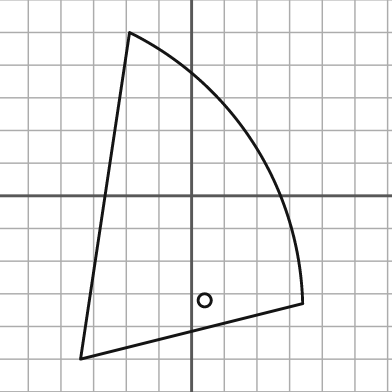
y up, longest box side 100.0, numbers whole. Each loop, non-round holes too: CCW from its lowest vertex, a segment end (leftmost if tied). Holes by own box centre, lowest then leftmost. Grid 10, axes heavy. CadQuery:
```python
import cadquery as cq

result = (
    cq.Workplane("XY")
    .moveTo(-34.0, -50.0)
    .lineTo(34.0, -33.0)
    .threePointArc((19.0, 16.0), (-19.0, 50.0))
    .close()
    .moveTo(4.0, -32.0)
    .circle(2.0)
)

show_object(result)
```